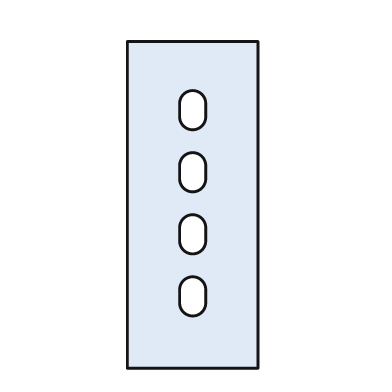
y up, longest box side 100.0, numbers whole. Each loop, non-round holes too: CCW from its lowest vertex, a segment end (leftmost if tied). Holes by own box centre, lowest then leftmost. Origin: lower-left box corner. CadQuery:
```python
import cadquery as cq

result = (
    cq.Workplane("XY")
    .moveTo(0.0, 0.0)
    .lineTo(40.0, 0.0)
    .lineTo(40.0, 100.0)
    .lineTo(0.0, 100.0)
    .close()
    .moveTo(16.0, 20.0)
    .threePointArc((20.0, 16.0), (24.0, 20.0))
    .lineTo(24.0, 24.0)
    .threePointArc((20.0, 28.0), (16.0, 24.0))
    .close()
    .moveTo(16.0, 39.0)
    .threePointArc((20.0, 35.0), (24.0, 39.0))
    .lineTo(24.0, 43.0)
    .threePointArc((20.0, 47.0), (16.0, 43.0))
    .close()
    .moveTo(16.0, 58.0)
    .threePointArc((20.0, 54.0), (24.0, 58.0))
    .lineTo(24.0, 62.0)
    .threePointArc((20.0, 66.0), (16.0, 62.0))
    .close()
    .moveTo(16.0, 77.0)
    .threePointArc((20.0, 73.0), (24.0, 77.0))
    .lineTo(24.0, 81.0)
    .threePointArc((20.0, 85.0), (16.0, 81.0))
    .close()
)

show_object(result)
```